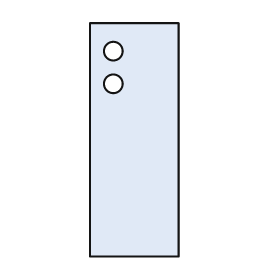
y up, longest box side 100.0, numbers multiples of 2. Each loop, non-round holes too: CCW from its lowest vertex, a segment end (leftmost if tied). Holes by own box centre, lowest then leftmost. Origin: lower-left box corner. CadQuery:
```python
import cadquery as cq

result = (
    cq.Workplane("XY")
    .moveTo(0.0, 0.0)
    .lineTo(38.0, 0.0)
    .lineTo(38.0, 100.0)
    .lineTo(0.0, 100.0)
    .close()
    .moveTo(10.0, 74.0)
    .circle(4.0)
    .moveTo(10.0, 88.0)
    .circle(4.0)
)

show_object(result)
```